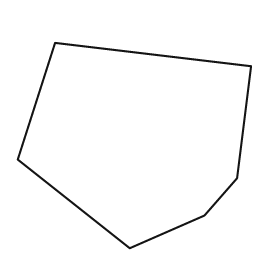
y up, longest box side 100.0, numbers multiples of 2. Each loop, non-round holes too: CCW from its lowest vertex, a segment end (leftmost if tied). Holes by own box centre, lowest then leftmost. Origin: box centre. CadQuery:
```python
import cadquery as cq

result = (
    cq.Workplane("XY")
    .moveTo(-2.0, -44.0)
    .lineTo(30.0, -30.0)
    .lineTo(44.0, -14.0)
    .lineTo(50.0, 34.0)
    .lineTo(-34.0, 44.0)
    .lineTo(-50.0, -6.0)
    .close()
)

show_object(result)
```